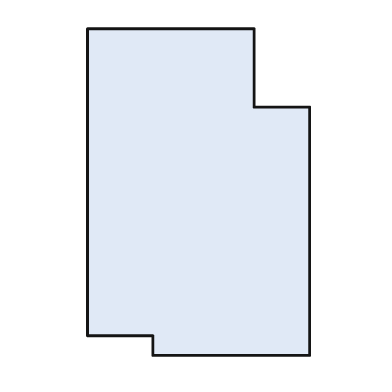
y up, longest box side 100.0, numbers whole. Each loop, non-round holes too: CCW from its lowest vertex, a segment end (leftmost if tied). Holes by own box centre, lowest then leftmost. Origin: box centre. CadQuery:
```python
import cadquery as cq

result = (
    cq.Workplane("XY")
    .moveTo(-14.0, -50.0)
    .lineTo(34.0, -50.0)
    .lineTo(34.0, 26.0)
    .lineTo(17.0, 26.0)
    .lineTo(17.0, 50.0)
    .lineTo(-34.0, 50.0)
    .lineTo(-34.0, -44.0)
    .lineTo(-14.0, -44.0)
    .close()
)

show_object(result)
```